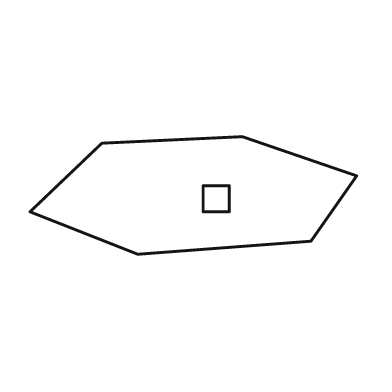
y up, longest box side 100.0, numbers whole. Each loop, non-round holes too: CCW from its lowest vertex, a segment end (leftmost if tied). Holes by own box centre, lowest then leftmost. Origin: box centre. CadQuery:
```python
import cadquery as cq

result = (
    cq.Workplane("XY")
    .moveTo(-17.0, -18.0)
    .lineTo(36.0, -14.0)
    .lineTo(50.0, 6.0)
    .lineTo(15.0, 18.0)
    .lineTo(-28.0, 16.0)
    .lineTo(-50.0, -5.0)
    .close()
    .moveTo(3.0, -5.0)
    .lineTo(11.0, -5.0)
    .lineTo(11.0, 3.0)
    .lineTo(3.0, 3.0)
    .close()
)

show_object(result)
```